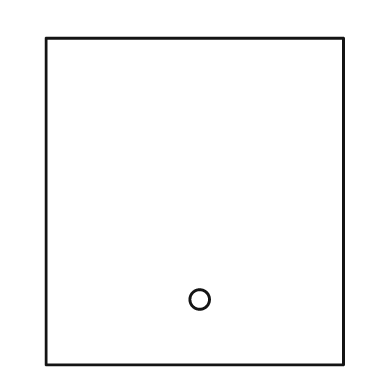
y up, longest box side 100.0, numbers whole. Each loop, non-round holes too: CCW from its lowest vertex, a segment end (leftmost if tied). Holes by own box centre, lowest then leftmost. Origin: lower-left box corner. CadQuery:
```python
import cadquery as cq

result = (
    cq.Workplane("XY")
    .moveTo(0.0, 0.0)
    .lineTo(91.0, 0.0)
    .lineTo(91.0, 100.0)
    .lineTo(0.0, 100.0)
    .close()
    .moveTo(47.0, 20.0)
    .circle(3.0)
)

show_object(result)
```